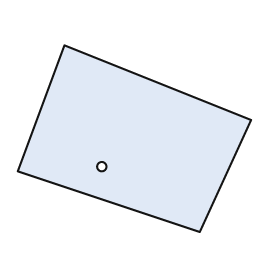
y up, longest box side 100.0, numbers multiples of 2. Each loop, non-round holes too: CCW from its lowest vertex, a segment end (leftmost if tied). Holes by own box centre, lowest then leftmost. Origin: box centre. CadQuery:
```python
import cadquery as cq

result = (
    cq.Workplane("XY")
    .moveTo(28.0, -40.0)
    .lineTo(50.0, 8.0)
    .lineTo(-30.0, 40.0)
    .lineTo(-50.0, -14.0)
    .close()
    .moveTo(-14.0, -12.0)
    .circle(2.0)
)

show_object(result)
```